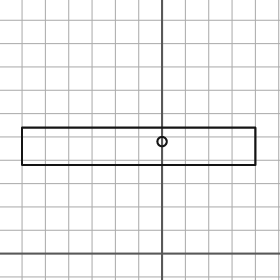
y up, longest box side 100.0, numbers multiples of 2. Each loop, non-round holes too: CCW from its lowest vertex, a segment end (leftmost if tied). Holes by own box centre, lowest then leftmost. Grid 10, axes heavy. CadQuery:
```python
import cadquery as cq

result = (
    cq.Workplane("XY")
    .moveTo(-60.0, 38.0)
    .lineTo(40.0, 38.0)
    .lineTo(40.0, 54.0)
    .lineTo(-60.0, 54.0)
    .close()
    .moveTo(0.0, 48.0)
    .circle(2.0)
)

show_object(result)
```